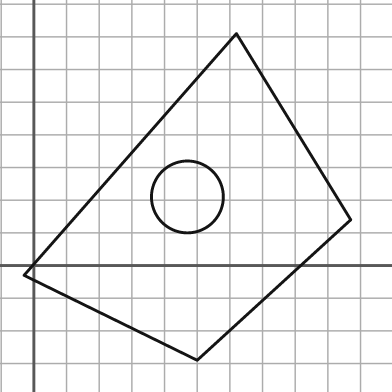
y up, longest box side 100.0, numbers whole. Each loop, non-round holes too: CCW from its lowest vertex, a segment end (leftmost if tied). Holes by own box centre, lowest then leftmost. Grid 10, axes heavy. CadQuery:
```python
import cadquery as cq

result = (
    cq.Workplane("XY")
    .moveTo(50.0, -29.0)
    .lineTo(97.0, 14.0)
    .lineTo(62.0, 71.0)
    .lineTo(-3.0, -3.0)
    .close()
    .moveTo(47.0, 21.0)
    .circle(11.0)
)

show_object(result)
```